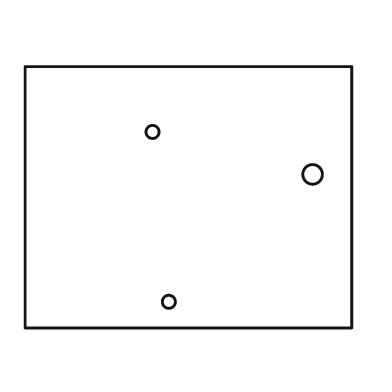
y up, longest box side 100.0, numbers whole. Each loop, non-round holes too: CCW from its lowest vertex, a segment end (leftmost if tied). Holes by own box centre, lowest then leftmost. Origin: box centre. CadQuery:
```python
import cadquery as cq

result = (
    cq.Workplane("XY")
    .moveTo(-50.0, -40.0)
    .lineTo(50.0, -40.0)
    .lineTo(50.0, 40.0)
    .lineTo(-50.0, 40.0)
    .close()
    .moveTo(-6.0, -32.0)
    .circle(2.0)
    .moveTo(38.0, 7.0)
    .circle(3.0)
    .moveTo(-11.0, 20.0)
    .circle(2.0)
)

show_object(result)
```